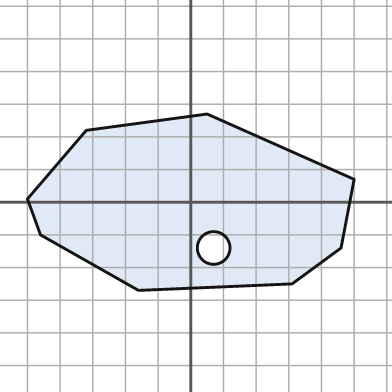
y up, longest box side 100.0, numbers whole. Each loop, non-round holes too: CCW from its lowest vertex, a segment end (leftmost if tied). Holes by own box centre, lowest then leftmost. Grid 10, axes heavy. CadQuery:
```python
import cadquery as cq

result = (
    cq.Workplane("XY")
    .moveTo(-16.0, -27.0)
    .lineTo(31.0, -25.0)
    .lineTo(46.0, -14.0)
    .lineTo(50.0, 7.0)
    .lineTo(5.0, 27.0)
    .lineTo(-32.0, 22.0)
    .lineTo(-50.0, 1.0)
    .lineTo(-46.0, -10.0)
    .close()
    .moveTo(7.0, -14.0)
    .circle(5.0)
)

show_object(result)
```